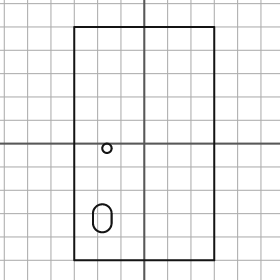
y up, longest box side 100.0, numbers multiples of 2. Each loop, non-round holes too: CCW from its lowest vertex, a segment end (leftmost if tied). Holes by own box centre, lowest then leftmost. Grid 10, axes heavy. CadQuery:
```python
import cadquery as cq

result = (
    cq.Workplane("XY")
    .moveTo(-30.0, -50.0)
    .lineTo(30.0, -50.0)
    .lineTo(30.0, 50.0)
    .lineTo(-30.0, 50.0)
    .close()
    .moveTo(-22.0, -34.0)
    .threePointArc((-18.0, -38.0), (-14.0, -34.0))
    .lineTo(-14.0, -30.0)
    .threePointArc((-18.0, -26.0), (-22.0, -30.0))
    .close()
    .moveTo(-16.0, -2.0)
    .circle(2.0)
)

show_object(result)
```